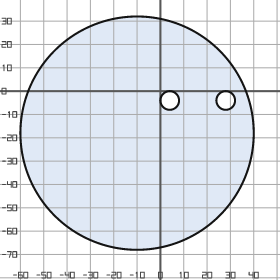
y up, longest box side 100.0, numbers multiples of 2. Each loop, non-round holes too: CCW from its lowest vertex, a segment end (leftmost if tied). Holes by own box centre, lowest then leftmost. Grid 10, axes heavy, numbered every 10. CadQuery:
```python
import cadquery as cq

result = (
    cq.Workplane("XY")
    .moveTo(-10.0, -18.0)
    .circle(50.0)
    .moveTo(4.0, -4.0)
    .circle(4.0)
    .moveTo(28.0, -4.0)
    .circle(4.0)
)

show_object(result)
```